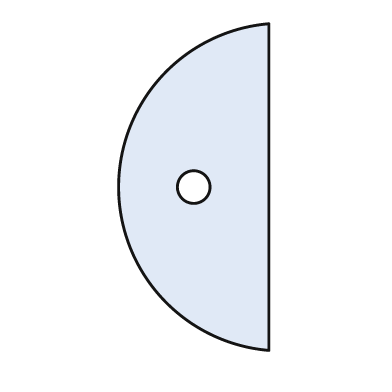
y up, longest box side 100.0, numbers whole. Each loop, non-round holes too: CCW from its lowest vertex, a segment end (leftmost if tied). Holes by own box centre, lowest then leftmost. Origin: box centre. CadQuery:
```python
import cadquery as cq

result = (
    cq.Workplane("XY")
    .moveTo(23.0, -50.0)
    .lineTo(23.0, 50.0)
    .threePointArc((-23.0, 0.0), (23.0, -50.0))
    .close()
    .moveTo(0.0, 0.0)
    .circle(5.0)
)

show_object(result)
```